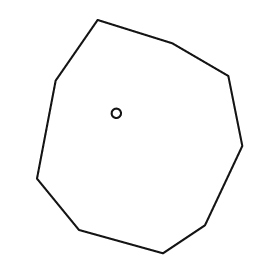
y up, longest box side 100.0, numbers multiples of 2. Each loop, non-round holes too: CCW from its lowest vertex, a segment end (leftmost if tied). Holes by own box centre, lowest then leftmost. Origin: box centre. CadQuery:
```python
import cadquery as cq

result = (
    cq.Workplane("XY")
    .moveTo(10.0, -50.0)
    .lineTo(28.0, -38.0)
    .lineTo(44.0, -4.0)
    .lineTo(38.0, 26.0)
    .lineTo(14.0, 40.0)
    .lineTo(-18.0, 50.0)
    .lineTo(-36.0, 24.0)
    .lineTo(-44.0, -18.0)
    .lineTo(-26.0, -40.0)
    .close()
    .moveTo(-10.0, 10.0)
    .circle(2.0)
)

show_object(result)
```